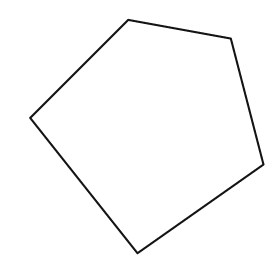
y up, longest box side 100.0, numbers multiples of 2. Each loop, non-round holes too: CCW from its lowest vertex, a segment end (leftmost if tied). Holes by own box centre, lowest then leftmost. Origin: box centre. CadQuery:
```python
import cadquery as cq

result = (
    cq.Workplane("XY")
    .moveTo(-4.0, -50.0)
    .lineTo(50.0, -12.0)
    .lineTo(36.0, 42.0)
    .lineTo(-8.0, 50.0)
    .lineTo(-50.0, 8.0)
    .close()
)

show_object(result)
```